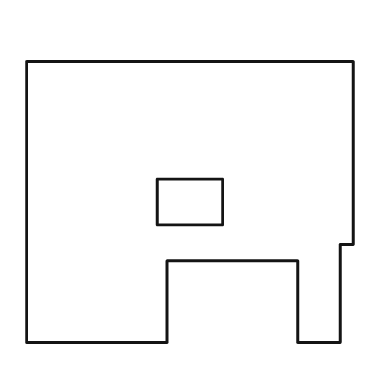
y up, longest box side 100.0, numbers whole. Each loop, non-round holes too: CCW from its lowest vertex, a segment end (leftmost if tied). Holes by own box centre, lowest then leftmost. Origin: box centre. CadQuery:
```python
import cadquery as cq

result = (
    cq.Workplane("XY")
    .moveTo(-50.0, -43.0)
    .lineTo(-7.0, -43.0)
    .lineTo(-7.0, -18.0)
    .lineTo(33.0, -18.0)
    .lineTo(33.0, -43.0)
    .lineTo(46.0, -43.0)
    .lineTo(46.0, -13.0)
    .lineTo(50.0, -13.0)
    .lineTo(50.0, 43.0)
    .lineTo(-50.0, 43.0)
    .close()
    .moveTo(-10.0, -7.0)
    .lineTo(10.0, -7.0)
    .lineTo(10.0, 7.0)
    .lineTo(-10.0, 7.0)
    .close()
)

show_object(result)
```